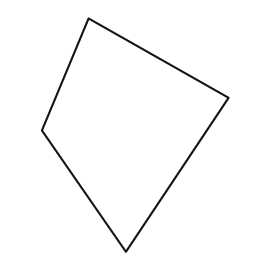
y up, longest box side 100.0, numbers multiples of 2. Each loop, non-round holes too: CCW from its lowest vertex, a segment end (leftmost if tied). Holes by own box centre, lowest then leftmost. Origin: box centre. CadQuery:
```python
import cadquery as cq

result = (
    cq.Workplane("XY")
    .moveTo(-4.0, -50.0)
    .lineTo(40.0, 16.0)
    .lineTo(-20.0, 50.0)
    .lineTo(-40.0, 2.0)
    .close()
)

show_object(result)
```